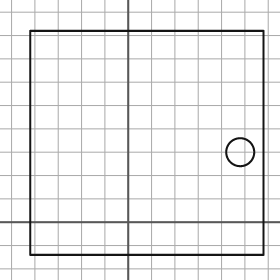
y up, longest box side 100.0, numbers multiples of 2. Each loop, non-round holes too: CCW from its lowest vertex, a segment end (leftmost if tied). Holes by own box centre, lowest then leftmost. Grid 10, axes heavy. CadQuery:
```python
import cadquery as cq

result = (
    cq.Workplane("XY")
    .moveTo(-42.0, -14.0)
    .lineTo(58.0, -14.0)
    .lineTo(58.0, 82.0)
    .lineTo(-42.0, 82.0)
    .close()
    .moveTo(48.0, 30.0)
    .circle(6.0)
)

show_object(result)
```